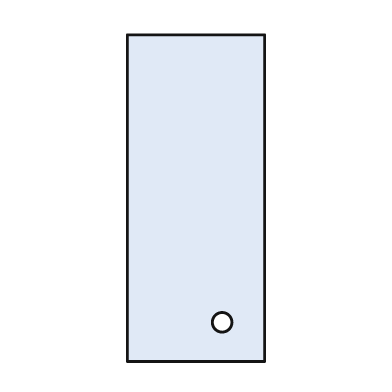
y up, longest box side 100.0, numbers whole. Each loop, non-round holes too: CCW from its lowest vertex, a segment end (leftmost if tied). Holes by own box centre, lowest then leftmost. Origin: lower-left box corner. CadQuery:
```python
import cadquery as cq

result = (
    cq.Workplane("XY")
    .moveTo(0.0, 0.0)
    .lineTo(42.0, 0.0)
    .lineTo(42.0, 100.0)
    .lineTo(0.0, 100.0)
    .close()
    .moveTo(29.0, 12.0)
    .circle(3.0)
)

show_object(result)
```